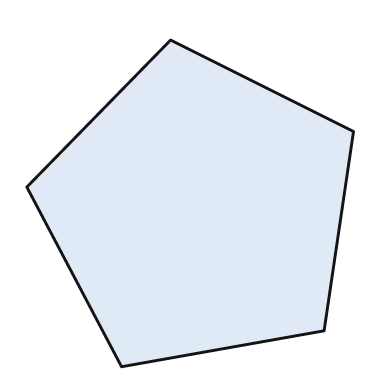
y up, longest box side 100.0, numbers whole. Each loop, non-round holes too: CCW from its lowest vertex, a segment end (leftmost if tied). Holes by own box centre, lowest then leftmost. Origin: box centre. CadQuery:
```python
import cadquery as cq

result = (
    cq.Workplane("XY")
    .moveTo(-21.0, -50.0)
    .lineTo(41.0, -39.0)
    .lineTo(50.0, 22.0)
    .lineTo(-6.0, 50.0)
    .lineTo(-50.0, 5.0)
    .close()
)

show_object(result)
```